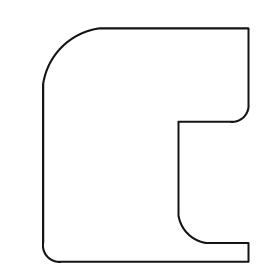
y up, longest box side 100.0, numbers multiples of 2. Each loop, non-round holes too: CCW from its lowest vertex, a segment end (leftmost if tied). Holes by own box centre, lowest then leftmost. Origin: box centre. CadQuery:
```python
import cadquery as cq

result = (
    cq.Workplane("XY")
    .moveTo(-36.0, -50.0)
    .lineTo(44.0, -50.0)
    .lineTo(44.0, -42.0)
    .lineTo(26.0, -42.0)
    .threePointArc((18.0, -38.0), (14.0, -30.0))
    .lineTo(14.0, 10.0)
    .lineTo(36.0, 10.0)
    .threePointArc((42.0, 12.0), (44.0, 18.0))
    .lineTo(44.0, 50.0)
    .lineTo(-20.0, 50.0)
    .threePointArc((-36.0, 42.0), (-44.0, 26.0))
    .lineTo(-44.0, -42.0)
    .threePointArc((-42.0, -48.0), (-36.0, -50.0))
    .close()
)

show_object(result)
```